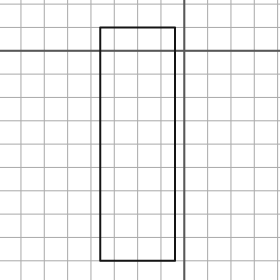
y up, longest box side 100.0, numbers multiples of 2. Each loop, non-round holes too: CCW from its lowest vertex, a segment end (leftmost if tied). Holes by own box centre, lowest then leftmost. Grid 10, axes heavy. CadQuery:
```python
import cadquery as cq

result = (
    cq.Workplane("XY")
    .moveTo(-36.0, -90.0)
    .lineTo(-4.0, -90.0)
    .lineTo(-4.0, 10.0)
    .lineTo(-36.0, 10.0)
    .close()
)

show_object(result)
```